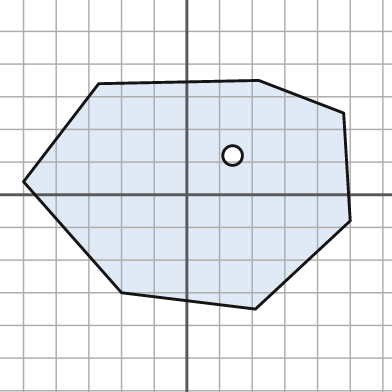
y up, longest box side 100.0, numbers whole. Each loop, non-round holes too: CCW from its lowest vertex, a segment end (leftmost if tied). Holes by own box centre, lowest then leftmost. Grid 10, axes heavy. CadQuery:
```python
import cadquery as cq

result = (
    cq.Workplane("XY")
    .moveTo(21.0, -35.0)
    .lineTo(50.0, -8.0)
    .lineTo(48.0, 25.0)
    .lineTo(22.0, 35.0)
    .lineTo(-27.0, 34.0)
    .lineTo(-50.0, 4.0)
    .lineTo(-20.0, -30.0)
    .close()
    .moveTo(14.0, 12.0)
    .circle(3.0)
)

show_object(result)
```